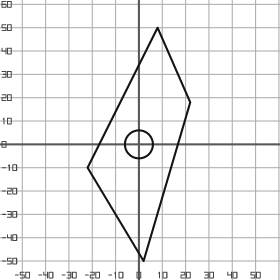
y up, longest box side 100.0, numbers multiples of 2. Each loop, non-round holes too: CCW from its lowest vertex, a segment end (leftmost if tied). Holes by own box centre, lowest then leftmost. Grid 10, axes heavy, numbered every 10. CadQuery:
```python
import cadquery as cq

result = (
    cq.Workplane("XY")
    .moveTo(2.0, -50.0)
    .lineTo(22.0, 18.0)
    .lineTo(8.0, 50.0)
    .lineTo(-22.0, -10.0)
    .close()
    .moveTo(0.0, 0.0)
    .circle(6.0)
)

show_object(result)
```